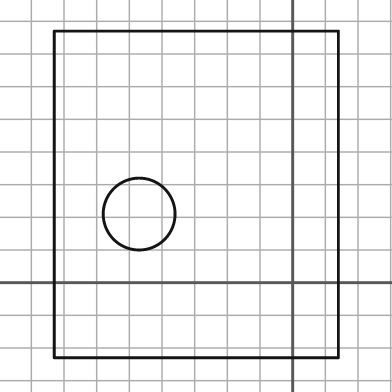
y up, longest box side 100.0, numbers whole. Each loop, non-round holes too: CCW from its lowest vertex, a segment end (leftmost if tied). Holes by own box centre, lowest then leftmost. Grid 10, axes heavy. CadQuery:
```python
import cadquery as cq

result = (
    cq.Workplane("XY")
    .moveTo(-73.0, -23.0)
    .lineTo(14.0, -23.0)
    .lineTo(14.0, 77.0)
    .lineTo(-73.0, 77.0)
    .close()
    .moveTo(-47.0, 21.0)
    .circle(11.0)
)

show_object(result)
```